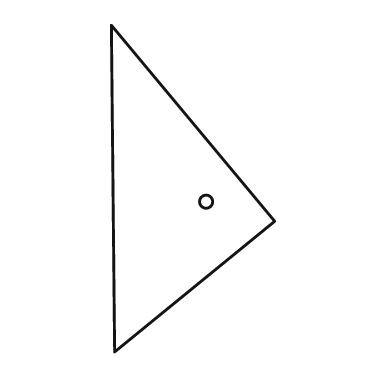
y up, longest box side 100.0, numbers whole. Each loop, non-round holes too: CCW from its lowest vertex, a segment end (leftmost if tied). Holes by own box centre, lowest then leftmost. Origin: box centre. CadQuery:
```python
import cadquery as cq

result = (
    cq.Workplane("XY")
    .moveTo(-24.0, -50.0)
    .lineTo(25.0, -10.0)
    .lineTo(-25.0, 50.0)
    .close()
    .moveTo(4.0, -4.0)
    .circle(2.0)
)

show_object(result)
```